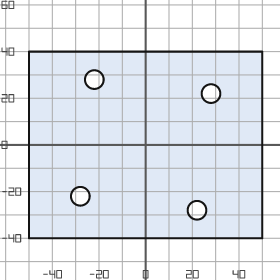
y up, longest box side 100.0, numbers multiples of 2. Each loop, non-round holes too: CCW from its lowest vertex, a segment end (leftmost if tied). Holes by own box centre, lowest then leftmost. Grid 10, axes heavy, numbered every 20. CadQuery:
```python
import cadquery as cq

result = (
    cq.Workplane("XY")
    .moveTo(-50.0, -40.0)
    .lineTo(50.0, -40.0)
    .lineTo(50.0, 40.0)
    .lineTo(-50.0, 40.0)
    .close()
    .moveTo(22.0, -28.0)
    .circle(4.0)
    .moveTo(-28.0, -22.0)
    .circle(4.0)
    .moveTo(28.0, 22.0)
    .circle(4.0)
    .moveTo(-22.0, 28.0)
    .circle(4.0)
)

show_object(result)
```